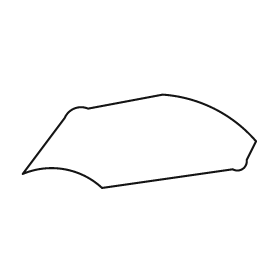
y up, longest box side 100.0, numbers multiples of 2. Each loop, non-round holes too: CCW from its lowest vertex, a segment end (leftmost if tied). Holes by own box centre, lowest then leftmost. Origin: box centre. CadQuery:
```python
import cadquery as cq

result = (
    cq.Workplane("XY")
    .moveTo(-16.0, -20.0)
    .lineTo(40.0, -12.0)
    .threePointArc((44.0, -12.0), (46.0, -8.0))
    .lineTo(50.0, 0.0)
    .threePointArc((32.0, 14.0), (10.0, 20.0))
    .lineTo(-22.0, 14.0)
    .threePointArc((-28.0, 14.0), (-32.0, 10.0))
    .lineTo(-50.0, -14.0)
    .threePointArc((-32.0, -12.0), (-16.0, -20.0))
    .close()
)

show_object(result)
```